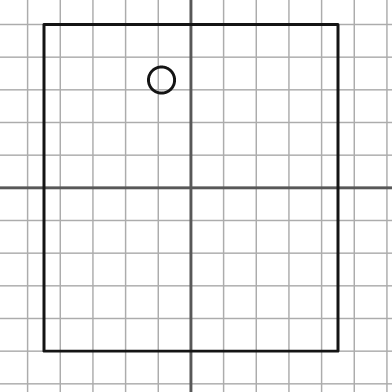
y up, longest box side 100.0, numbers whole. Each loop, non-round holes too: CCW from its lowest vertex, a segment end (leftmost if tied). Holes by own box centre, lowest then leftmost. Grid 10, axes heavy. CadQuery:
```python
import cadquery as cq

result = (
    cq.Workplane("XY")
    .moveTo(-45.0, -50.0)
    .lineTo(45.0, -50.0)
    .lineTo(45.0, 50.0)
    .lineTo(-45.0, 50.0)
    .close()
    .moveTo(-9.0, 33.0)
    .circle(4.0)
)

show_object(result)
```